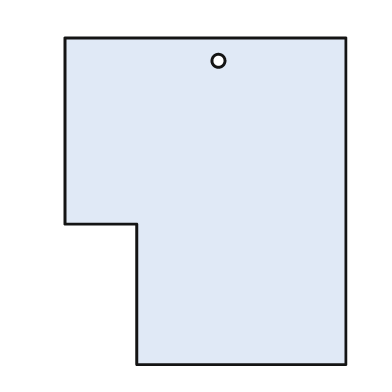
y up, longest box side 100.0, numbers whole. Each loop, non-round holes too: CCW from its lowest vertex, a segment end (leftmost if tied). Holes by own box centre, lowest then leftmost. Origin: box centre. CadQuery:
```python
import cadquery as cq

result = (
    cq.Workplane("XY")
    .moveTo(-21.0, -50.0)
    .lineTo(43.0, -50.0)
    .lineTo(43.0, 50.0)
    .lineTo(-43.0, 50.0)
    .lineTo(-43.0, -7.0)
    .lineTo(-21.0, -7.0)
    .close()
    .moveTo(4.0, 43.0)
    .circle(2.0)
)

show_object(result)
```